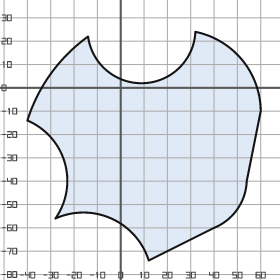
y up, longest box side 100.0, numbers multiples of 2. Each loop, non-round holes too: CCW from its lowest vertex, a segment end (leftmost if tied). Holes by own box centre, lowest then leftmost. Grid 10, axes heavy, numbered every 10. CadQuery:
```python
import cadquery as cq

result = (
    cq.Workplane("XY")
    .moveTo(12.0, -74.0)
    .lineTo(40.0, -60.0)
    .threePointArc((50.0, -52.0), (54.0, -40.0))
    .lineTo(60.0, -10.0)
    .threePointArc((52.0, 12.0), (32.0, 24.0))
    .threePointArc((10.0, 2.0), (-14.0, 22.0))
    .threePointArc((-30.0, 6.0), (-40.0, -14.0))
    .threePointArc((-24.0, -32.0), (-28.0, -56.0))
    .threePointArc((-4.0, -56.0), (12.0, -74.0))
    .close()
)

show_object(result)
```